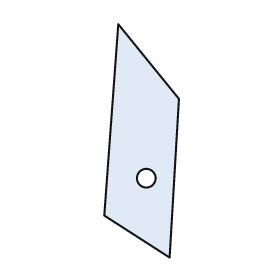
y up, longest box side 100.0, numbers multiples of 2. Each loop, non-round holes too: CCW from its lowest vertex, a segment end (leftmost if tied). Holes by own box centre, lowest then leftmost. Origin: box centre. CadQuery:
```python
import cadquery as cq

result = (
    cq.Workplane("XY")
    .moveTo(12.0, -50.0)
    .lineTo(16.0, 18.0)
    .lineTo(-10.0, 50.0)
    .lineTo(-16.0, -32.0)
    .close()
    .moveTo(2.0, -16.0)
    .circle(4.0)
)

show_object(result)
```